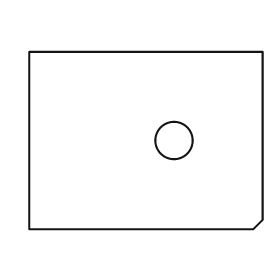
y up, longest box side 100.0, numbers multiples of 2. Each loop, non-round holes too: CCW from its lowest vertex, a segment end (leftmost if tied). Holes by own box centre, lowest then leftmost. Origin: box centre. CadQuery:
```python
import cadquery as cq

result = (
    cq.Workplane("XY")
    .moveTo(-50.0, -38.0)
    .lineTo(46.0, -38.0)
    .lineTo(50.0, -34.0)
    .lineTo(50.0, 38.0)
    .lineTo(-50.0, 38.0)
    .close()
    .moveTo(12.0, 0.0)
    .circle(8.0)
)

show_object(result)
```